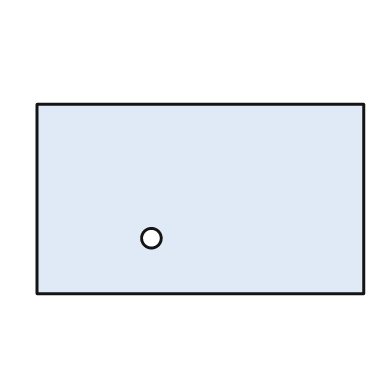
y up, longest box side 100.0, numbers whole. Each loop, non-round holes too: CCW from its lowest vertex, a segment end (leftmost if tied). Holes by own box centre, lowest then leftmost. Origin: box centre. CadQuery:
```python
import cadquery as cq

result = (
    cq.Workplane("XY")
    .moveTo(-50.0, -29.0)
    .lineTo(50.0, -29.0)
    .lineTo(50.0, 29.0)
    .lineTo(-50.0, 29.0)
    .close()
    .moveTo(-15.0, -12.0)
    .circle(3.0)
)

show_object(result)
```